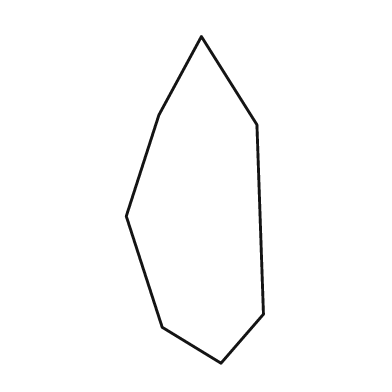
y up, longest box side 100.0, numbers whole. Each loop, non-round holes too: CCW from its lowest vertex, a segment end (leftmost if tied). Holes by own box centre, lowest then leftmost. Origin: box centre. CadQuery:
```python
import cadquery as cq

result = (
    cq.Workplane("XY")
    .moveTo(8.0, -50.0)
    .lineTo(21.0, -35.0)
    .lineTo(19.0, 23.0)
    .lineTo(2.0, 50.0)
    .lineTo(-11.0, 26.0)
    .lineTo(-21.0, -5.0)
    .lineTo(-10.0, -39.0)
    .close()
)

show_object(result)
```